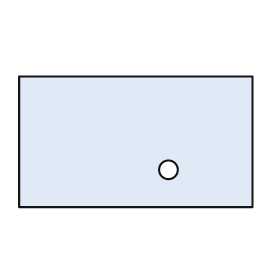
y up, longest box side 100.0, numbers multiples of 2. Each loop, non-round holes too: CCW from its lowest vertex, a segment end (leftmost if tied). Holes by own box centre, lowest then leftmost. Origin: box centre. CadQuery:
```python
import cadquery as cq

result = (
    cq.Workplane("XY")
    .moveTo(-50.0, -28.0)
    .lineTo(50.0, -28.0)
    .lineTo(50.0, 28.0)
    .lineTo(-50.0, 28.0)
    .close()
    .moveTo(14.0, -12.0)
    .circle(4.0)
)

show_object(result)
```